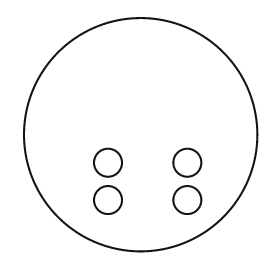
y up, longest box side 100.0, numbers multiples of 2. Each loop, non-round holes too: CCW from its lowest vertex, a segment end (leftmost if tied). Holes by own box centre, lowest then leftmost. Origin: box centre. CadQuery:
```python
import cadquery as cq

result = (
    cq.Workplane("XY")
    .moveTo(0.0, 0.0)
    .circle(50.0)
    .moveTo(-14.0, -28.0)
    .circle(6.0)
    .moveTo(20.0, -28.0)
    .circle(6.0)
    .moveTo(-14.0, -12.0)
    .circle(6.0)
    .moveTo(20.0, -12.0)
    .circle(6.0)
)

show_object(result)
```